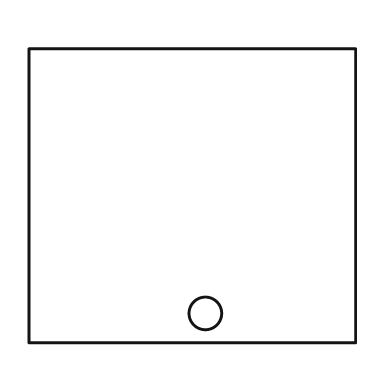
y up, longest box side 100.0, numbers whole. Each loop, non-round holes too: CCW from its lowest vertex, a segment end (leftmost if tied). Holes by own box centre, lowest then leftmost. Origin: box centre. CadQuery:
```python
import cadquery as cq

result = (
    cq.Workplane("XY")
    .moveTo(-50.0, -45.0)
    .lineTo(50.0, -45.0)
    .lineTo(50.0, 45.0)
    .lineTo(-50.0, 45.0)
    .close()
    .moveTo(4.0, -36.0)
    .circle(5.0)
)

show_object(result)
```